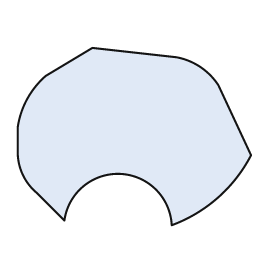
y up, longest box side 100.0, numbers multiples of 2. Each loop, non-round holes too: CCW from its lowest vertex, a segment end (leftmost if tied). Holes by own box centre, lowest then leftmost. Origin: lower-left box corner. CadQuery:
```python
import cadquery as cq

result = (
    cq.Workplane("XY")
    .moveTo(66.0, 0.0)
    .threePointArc((86.0, 12.0), (100.0, 30.0))
    .lineTo(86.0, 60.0)
    .threePointArc((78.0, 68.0), (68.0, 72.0))
    .lineTo(32.0, 76.0)
    .lineTo(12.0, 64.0)
    .threePointArc((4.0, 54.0), (0.0, 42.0))
    .lineTo(0.0, 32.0)
    .threePointArc((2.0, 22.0), (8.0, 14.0))
    .lineTo(20.0, 2.0)
    .threePointArc((44.0, 22.0), (66.0, 0.0))
    .close()
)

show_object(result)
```